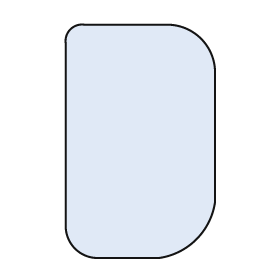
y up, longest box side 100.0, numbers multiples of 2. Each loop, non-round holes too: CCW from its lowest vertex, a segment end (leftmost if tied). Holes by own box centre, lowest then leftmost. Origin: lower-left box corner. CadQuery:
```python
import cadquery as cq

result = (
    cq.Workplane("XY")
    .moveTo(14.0, 0.0)
    .lineTo(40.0, 0.0)
    .threePointArc((56.0, 8.0), (64.0, 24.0))
    .lineTo(64.0, 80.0)
    .threePointArc((58.0, 94.0), (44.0, 100.0))
    .lineTo(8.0, 100.0)
    .threePointArc((2.0, 98.0), (0.0, 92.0))
    .lineTo(0.0, 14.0)
    .threePointArc((4.0, 4.0), (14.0, 0.0))
    .close()
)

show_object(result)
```